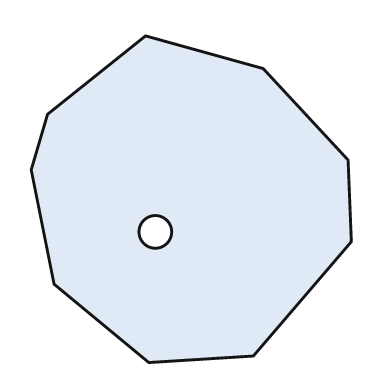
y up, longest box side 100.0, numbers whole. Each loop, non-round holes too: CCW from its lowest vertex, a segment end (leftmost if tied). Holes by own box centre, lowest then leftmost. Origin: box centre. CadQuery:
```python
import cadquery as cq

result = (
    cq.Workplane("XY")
    .moveTo(-13.0, -50.0)
    .lineTo(19.0, -48.0)
    .lineTo(49.0, -13.0)
    .lineTo(48.0, 12.0)
    .lineTo(22.0, 40.0)
    .lineTo(-14.0, 50.0)
    .lineTo(-44.0, 26.0)
    .lineTo(-49.0, 9.0)
    .lineTo(-42.0, -26.0)
    .close()
    .moveTo(-11.0, -10.0)
    .circle(5.0)
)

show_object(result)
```